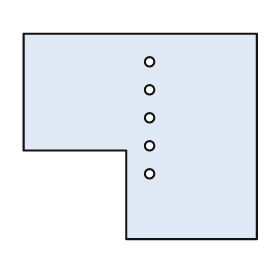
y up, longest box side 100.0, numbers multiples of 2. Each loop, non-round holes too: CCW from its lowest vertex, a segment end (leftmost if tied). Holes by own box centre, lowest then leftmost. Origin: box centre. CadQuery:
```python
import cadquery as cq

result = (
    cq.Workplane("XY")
    .moveTo(-6.0, -44.0)
    .lineTo(50.0, -44.0)
    .lineTo(50.0, 44.0)
    .lineTo(-50.0, 44.0)
    .lineTo(-50.0, -6.0)
    .lineTo(-6.0, -6.0)
    .close()
    .moveTo(4.0, -16.0)
    .circle(2.0)
    .moveTo(4.0, -4.0)
    .circle(2.0)
    .moveTo(4.0, 8.0)
    .circle(2.0)
    .moveTo(4.0, 20.0)
    .circle(2.0)
    .moveTo(4.0, 32.0)
    .circle(2.0)
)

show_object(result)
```